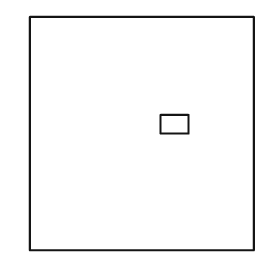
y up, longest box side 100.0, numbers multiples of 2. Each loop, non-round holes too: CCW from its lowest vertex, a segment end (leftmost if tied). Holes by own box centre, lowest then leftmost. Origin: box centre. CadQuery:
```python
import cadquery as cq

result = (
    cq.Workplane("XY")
    .moveTo(-48.0, -50.0)
    .lineTo(48.0, -50.0)
    .lineTo(48.0, 50.0)
    .lineTo(-48.0, 50.0)
    .close()
    .moveTo(8.0, 0.0)
    .lineTo(20.0, 0.0)
    .lineTo(20.0, 8.0)
    .lineTo(8.0, 8.0)
    .close()
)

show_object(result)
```